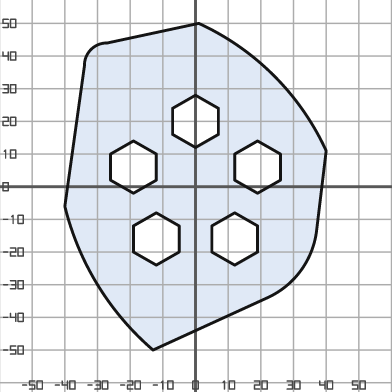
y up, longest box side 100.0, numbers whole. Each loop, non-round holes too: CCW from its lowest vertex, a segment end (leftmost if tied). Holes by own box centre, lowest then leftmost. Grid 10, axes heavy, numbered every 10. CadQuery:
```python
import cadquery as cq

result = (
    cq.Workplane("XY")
    .moveTo(-13.0, -50.0)
    .lineTo(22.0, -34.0)
    .threePointArc((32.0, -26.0), (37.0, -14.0))
    .lineTo(40.0, 11.0)
    .threePointArc((24.0, 34.0), (1.0, 50.0))
    .lineTo(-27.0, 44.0)
    .threePointArc((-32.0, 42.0), (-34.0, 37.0))
    .lineTo(-40.0, -6.0)
    .threePointArc((-30.0, -30.0), (-13.0, -50.0))
    .close()
    .moveTo(-12.0, -24.0)
    .lineTo(-5.0, -20.0)
    .lineTo(-5.0, -12.0)
    .lineTo(-12.0, -8.0)
    .lineTo(-19.0, -12.0)
    .lineTo(-19.0, -20.0)
    .close()
    .moveTo(12.0, -24.0)
    .lineTo(19.0, -20.0)
    .lineTo(19.0, -12.0)
    .lineTo(12.0, -8.0)
    .lineTo(5.0, -12.0)
    .lineTo(5.0, -20.0)
    .close()
    .moveTo(-19.0, -2.0)
    .lineTo(-12.0, 2.0)
    .lineTo(-12.0, 10.0)
    .lineTo(-19.0, 14.0)
    .lineTo(-26.0, 10.0)
    .lineTo(-26.0, 2.0)
    .close()
    .moveTo(19.0, -2.0)
    .lineTo(26.0, 2.0)
    .lineTo(26.0, 10.0)
    .lineTo(19.0, 14.0)
    .lineTo(12.0, 10.0)
    .lineTo(12.0, 2.0)
    .close()
    .moveTo(0.0, 12.0)
    .lineTo(7.0, 16.0)
    .lineTo(7.0, 24.0)
    .lineTo(0.0, 28.0)
    .lineTo(-7.0, 24.0)
    .lineTo(-7.0, 16.0)
    .close()
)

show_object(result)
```